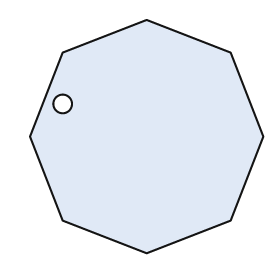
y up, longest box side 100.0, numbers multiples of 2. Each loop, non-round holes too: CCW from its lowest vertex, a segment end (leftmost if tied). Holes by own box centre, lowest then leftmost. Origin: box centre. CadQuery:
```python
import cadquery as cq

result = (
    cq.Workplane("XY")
    .moveTo(0.0, -50.0)
    .lineTo(36.0, -36.0)
    .lineTo(50.0, 0.0)
    .lineTo(36.0, 36.0)
    .lineTo(0.0, 50.0)
    .lineTo(-36.0, 36.0)
    .lineTo(-50.0, 0.0)
    .lineTo(-36.0, -36.0)
    .close()
    .moveTo(-36.0, 14.0)
    .circle(4.0)
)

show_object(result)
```